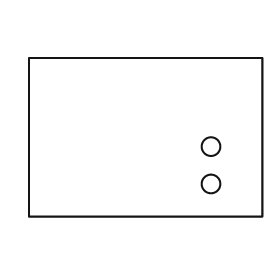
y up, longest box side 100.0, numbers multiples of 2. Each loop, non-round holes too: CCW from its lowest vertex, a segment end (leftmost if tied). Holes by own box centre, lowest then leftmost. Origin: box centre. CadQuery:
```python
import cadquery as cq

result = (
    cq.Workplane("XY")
    .moveTo(-50.0, -34.0)
    .lineTo(50.0, -34.0)
    .lineTo(50.0, 34.0)
    .lineTo(-50.0, 34.0)
    .close()
    .moveTo(28.0, -20.0)
    .circle(4.0)
    .moveTo(28.0, -4.0)
    .circle(4.0)
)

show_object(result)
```